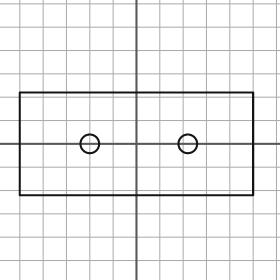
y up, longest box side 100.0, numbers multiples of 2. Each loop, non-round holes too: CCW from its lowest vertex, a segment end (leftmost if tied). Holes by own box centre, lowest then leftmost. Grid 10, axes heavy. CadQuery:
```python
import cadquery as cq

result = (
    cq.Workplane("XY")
    .moveTo(-50.0, -22.0)
    .lineTo(50.0, -22.0)
    .lineTo(50.0, 22.0)
    .lineTo(-50.0, 22.0)
    .close()
    .moveTo(-20.0, 0.0)
    .circle(4.0)
    .moveTo(22.0, 0.0)
    .circle(4.0)
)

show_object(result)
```